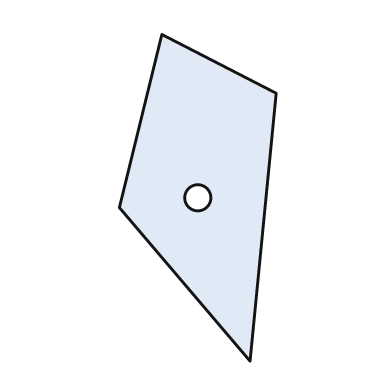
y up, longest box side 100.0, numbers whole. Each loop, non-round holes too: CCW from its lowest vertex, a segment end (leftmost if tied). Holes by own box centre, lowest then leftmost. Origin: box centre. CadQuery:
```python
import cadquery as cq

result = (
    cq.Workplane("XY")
    .moveTo(16.0, -50.0)
    .lineTo(24.0, 32.0)
    .lineTo(-11.0, 50.0)
    .lineTo(-24.0, -3.0)
    .close()
    .moveTo(0.0, 0.0)
    .circle(4.0)
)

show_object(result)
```